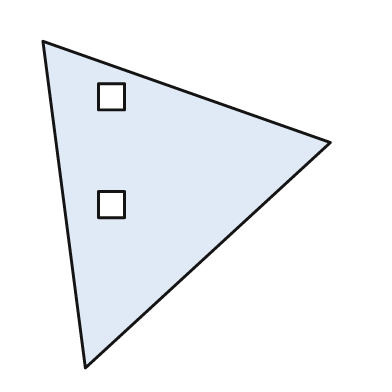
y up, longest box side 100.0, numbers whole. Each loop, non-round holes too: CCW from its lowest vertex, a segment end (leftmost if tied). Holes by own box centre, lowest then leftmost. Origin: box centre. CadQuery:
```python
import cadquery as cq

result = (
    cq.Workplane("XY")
    .moveTo(-31.0, -50.0)
    .lineTo(44.0, 19.0)
    .lineTo(-44.0, 50.0)
    .close()
    .moveTo(-27.0, -4.0)
    .lineTo(-19.0, -4.0)
    .lineTo(-19.0, 4.0)
    .lineTo(-27.0, 4.0)
    .close()
    .moveTo(-27.0, 29.0)
    .lineTo(-19.0, 29.0)
    .lineTo(-19.0, 37.0)
    .lineTo(-27.0, 37.0)
    .close()
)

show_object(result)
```